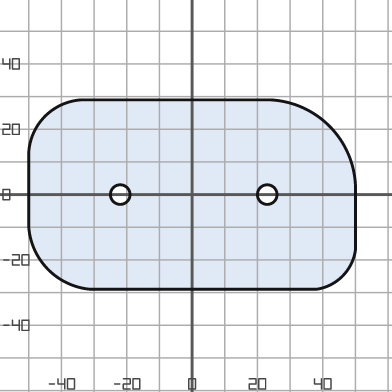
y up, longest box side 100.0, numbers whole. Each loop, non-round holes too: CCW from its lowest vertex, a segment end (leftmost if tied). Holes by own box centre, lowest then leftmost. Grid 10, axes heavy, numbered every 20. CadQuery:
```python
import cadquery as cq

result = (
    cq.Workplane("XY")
    .moveTo(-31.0, -29.0)
    .lineTo(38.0, -29.0)
    .threePointArc((46.0, -25.0), (50.0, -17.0))
    .lineTo(50.0, 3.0)
    .threePointArc((42.0, 21.0), (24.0, 29.0))
    .lineTo(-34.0, 29.0)
    .threePointArc((-45.0, 24.0), (-50.0, 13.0))
    .lineTo(-50.0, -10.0)
    .threePointArc((-44.0, -23.0), (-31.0, -29.0))
    .close()
    .moveTo(-22.0, 0.0)
    .circle(3.0)
    .moveTo(23.0, 0.0)
    .circle(3.0)
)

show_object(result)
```